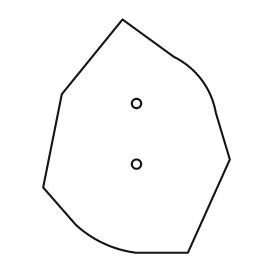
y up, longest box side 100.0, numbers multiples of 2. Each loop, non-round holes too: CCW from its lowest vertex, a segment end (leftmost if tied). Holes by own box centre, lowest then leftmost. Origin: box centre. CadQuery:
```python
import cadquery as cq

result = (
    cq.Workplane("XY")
    .moveTo(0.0, -50.0)
    .lineTo(22.0, -50.0)
    .lineTo(40.0, -10.0)
    .lineTo(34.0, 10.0)
    .threePointArc((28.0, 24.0), (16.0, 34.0))
    .lineTo(-6.0, 50.0)
    .lineTo(-32.0, 18.0)
    .lineTo(-40.0, -22.0)
    .lineTo(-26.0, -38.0)
    .threePointArc((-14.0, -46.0), (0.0, -50.0))
    .close()
    .moveTo(0.0, -12.0)
    .circle(2.0)
    .moveTo(0.0, 14.0)
    .circle(2.0)
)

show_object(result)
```